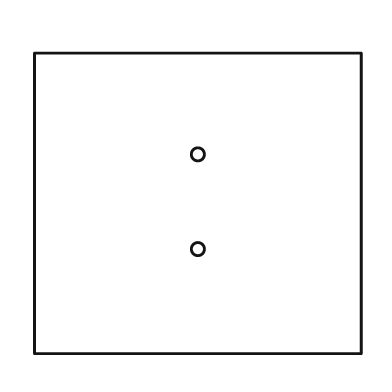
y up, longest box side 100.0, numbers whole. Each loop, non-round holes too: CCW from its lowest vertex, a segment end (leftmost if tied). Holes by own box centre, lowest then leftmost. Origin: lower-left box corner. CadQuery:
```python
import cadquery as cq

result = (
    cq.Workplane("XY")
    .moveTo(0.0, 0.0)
    .lineTo(100.0, 0.0)
    .lineTo(100.0, 92.0)
    .lineTo(0.0, 92.0)
    .close()
    .moveTo(50.0, 32.0)
    .circle(2.0)
    .moveTo(50.0, 61.0)
    .circle(2.0)
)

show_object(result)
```